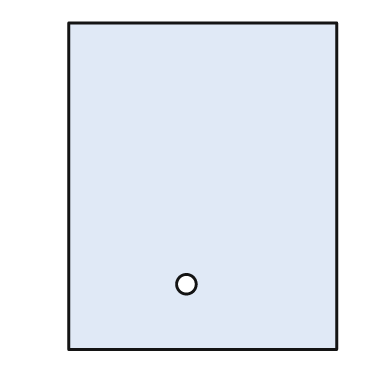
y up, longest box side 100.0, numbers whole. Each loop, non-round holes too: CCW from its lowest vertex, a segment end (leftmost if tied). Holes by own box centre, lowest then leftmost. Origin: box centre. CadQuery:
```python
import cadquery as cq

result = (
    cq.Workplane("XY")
    .moveTo(-41.0, -50.0)
    .lineTo(41.0, -50.0)
    .lineTo(41.0, 50.0)
    .lineTo(-41.0, 50.0)
    .close()
    .moveTo(-5.0, -30.0)
    .circle(3.0)
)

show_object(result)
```